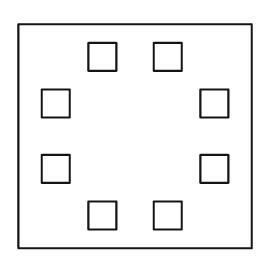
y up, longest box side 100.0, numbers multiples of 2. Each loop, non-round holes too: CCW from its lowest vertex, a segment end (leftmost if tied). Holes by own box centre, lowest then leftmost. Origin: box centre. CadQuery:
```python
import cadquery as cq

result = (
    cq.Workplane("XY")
    .moveTo(-50.0, -48.0)
    .lineTo(50.0, -48.0)
    .lineTo(50.0, 48.0)
    .lineTo(-50.0, 48.0)
    .close()
    .moveTo(-20.0, -40.0)
    .lineTo(-8.0, -40.0)
    .lineTo(-8.0, -28.0)
    .lineTo(-20.0, -28.0)
    .close()
    .moveTo(8.0, -40.0)
    .lineTo(20.0, -40.0)
    .lineTo(20.0, -28.0)
    .lineTo(8.0, -28.0)
    .close()
    .moveTo(-40.0, -20.0)
    .lineTo(-28.0, -20.0)
    .lineTo(-28.0, -8.0)
    .lineTo(-40.0, -8.0)
    .close()
    .moveTo(28.0, -20.0)
    .lineTo(40.0, -20.0)
    .lineTo(40.0, -8.0)
    .lineTo(28.0, -8.0)
    .close()
    .moveTo(-40.0, 8.0)
    .lineTo(-28.0, 8.0)
    .lineTo(-28.0, 20.0)
    .lineTo(-40.0, 20.0)
    .close()
    .moveTo(28.0, 8.0)
    .lineTo(40.0, 8.0)
    .lineTo(40.0, 20.0)
    .lineTo(28.0, 20.0)
    .close()
    .moveTo(-20.0, 28.0)
    .lineTo(-8.0, 28.0)
    .lineTo(-8.0, 40.0)
    .lineTo(-20.0, 40.0)
    .close()
    .moveTo(8.0, 28.0)
    .lineTo(20.0, 28.0)
    .lineTo(20.0, 40.0)
    .lineTo(8.0, 40.0)
    .close()
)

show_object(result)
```